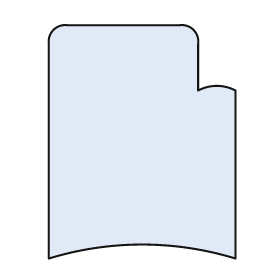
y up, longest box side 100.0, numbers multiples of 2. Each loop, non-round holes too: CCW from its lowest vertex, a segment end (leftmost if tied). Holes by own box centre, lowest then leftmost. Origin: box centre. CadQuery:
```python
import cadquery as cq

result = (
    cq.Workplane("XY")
    .moveTo(-40.0, -50.0)
    .threePointArc((0.0, -44.0), (40.0, -50.0))
    .lineTo(40.0, 22.0)
    .threePointArc((32.0, 24.0), (24.0, 22.0))
    .lineTo(24.0, 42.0)
    .threePointArc((22.0, 48.0), (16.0, 50.0))
    .lineTo(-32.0, 50.0)
    .threePointArc((-38.0, 48.0), (-40.0, 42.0))
    .close()
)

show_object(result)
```